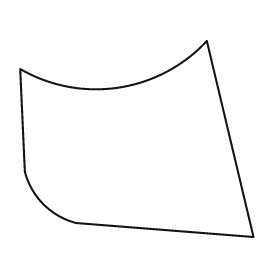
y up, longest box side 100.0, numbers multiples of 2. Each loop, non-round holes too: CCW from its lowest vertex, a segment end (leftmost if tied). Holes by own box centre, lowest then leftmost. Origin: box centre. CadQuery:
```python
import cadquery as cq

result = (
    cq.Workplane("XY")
    .moveTo(50.0, -42.0)
    .lineTo(30.0, 42.0)
    .threePointArc((-8.0, 22.0), (-50.0, 30.0))
    .lineTo(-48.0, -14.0)
    .threePointArc((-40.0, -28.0), (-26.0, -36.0))
    .close()
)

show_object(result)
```